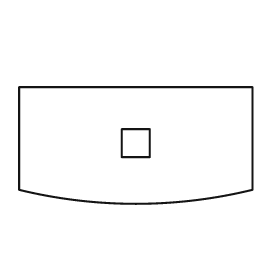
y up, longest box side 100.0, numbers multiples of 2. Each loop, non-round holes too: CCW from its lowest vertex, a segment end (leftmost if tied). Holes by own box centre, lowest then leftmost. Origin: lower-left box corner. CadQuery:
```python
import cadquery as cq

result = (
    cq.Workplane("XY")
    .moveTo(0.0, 6.0)
    .threePointArc((50.0, 0.0), (100.0, 6.0))
    .lineTo(100.0, 50.0)
    .lineTo(0.0, 50.0)
    .close()
    .moveTo(44.0, 20.0)
    .lineTo(56.0, 20.0)
    .lineTo(56.0, 32.0)
    .lineTo(44.0, 32.0)
    .close()
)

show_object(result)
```